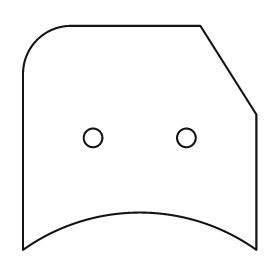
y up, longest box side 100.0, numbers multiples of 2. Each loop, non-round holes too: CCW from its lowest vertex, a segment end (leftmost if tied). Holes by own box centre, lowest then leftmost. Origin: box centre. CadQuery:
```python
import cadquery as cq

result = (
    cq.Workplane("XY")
    .moveTo(-50.0, -48.0)
    .threePointArc((0.0, -32.0), (50.0, -48.0))
    .lineTo(50.0, 10.0)
    .lineTo(26.0, 48.0)
    .lineTo(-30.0, 48.0)
    .threePointArc((-44.0, 42.0), (-50.0, 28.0))
    .close()
    .moveTo(-20.0, 0.0)
    .circle(4.0)
    .moveTo(20.0, 0.0)
    .circle(4.0)
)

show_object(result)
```